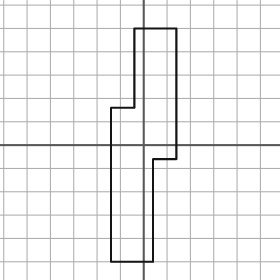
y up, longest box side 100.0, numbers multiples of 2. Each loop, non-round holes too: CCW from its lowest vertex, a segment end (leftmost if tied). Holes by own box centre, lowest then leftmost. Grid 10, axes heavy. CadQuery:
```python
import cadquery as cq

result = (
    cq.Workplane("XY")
    .moveTo(-14.0, -50.0)
    .lineTo(4.0, -50.0)
    .lineTo(4.0, -6.0)
    .lineTo(14.0, -6.0)
    .lineTo(14.0, 50.0)
    .lineTo(-4.0, 50.0)
    .lineTo(-4.0, 16.0)
    .lineTo(-14.0, 16.0)
    .close()
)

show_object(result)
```